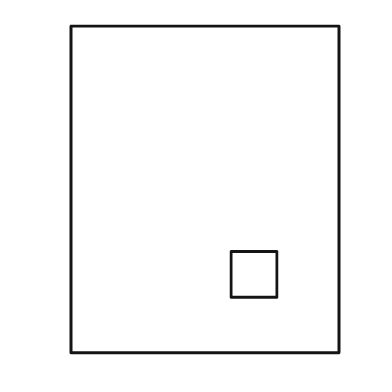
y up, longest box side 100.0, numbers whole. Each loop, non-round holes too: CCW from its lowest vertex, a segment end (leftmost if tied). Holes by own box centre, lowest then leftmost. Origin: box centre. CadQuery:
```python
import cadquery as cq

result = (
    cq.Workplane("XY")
    .moveTo(-41.0, -50.0)
    .lineTo(41.0, -50.0)
    .lineTo(41.0, 50.0)
    .lineTo(-41.0, 50.0)
    .close()
    .moveTo(8.0, -33.0)
    .lineTo(22.0, -33.0)
    .lineTo(22.0, -19.0)
    .lineTo(8.0, -19.0)
    .close()
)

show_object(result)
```